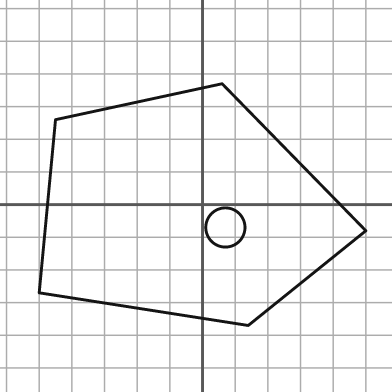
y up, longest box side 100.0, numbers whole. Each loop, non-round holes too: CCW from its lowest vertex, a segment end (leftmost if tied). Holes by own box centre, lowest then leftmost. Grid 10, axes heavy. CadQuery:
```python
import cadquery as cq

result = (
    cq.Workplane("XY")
    .moveTo(14.0, -37.0)
    .lineTo(50.0, -8.0)
    .lineTo(6.0, 37.0)
    .lineTo(-45.0, 26.0)
    .lineTo(-50.0, -27.0)
    .close()
    .moveTo(7.0, -7.0)
    .circle(6.0)
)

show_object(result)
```